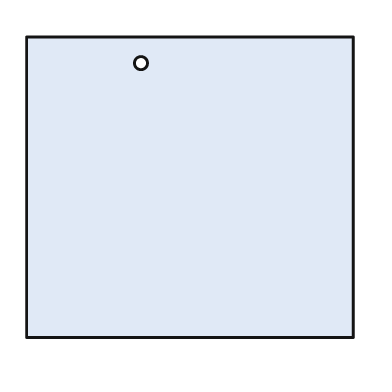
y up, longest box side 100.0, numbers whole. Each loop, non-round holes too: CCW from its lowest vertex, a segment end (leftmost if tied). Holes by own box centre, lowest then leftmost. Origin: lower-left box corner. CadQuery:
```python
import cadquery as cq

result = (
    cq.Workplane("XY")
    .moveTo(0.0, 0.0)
    .lineTo(100.0, 0.0)
    .lineTo(100.0, 92.0)
    .lineTo(0.0, 92.0)
    .close()
    .moveTo(35.0, 84.0)
    .circle(2.0)
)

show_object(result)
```